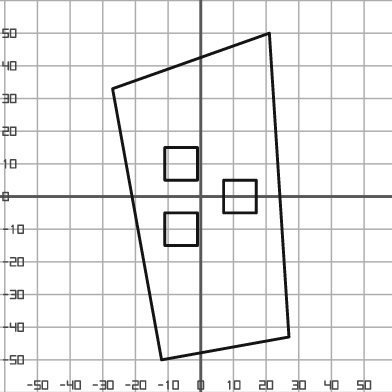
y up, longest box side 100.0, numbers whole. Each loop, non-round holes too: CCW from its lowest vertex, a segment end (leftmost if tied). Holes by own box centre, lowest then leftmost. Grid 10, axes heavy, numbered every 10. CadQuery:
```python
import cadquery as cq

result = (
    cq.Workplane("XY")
    .moveTo(-12.0, -50.0)
    .lineTo(27.0, -43.0)
    .lineTo(21.0, 50.0)
    .lineTo(-27.0, 33.0)
    .close()
    .moveTo(-11.0, -15.0)
    .lineTo(-1.0, -15.0)
    .lineTo(-1.0, -5.0)
    .lineTo(-11.0, -5.0)
    .close()
    .moveTo(7.0, -5.0)
    .lineTo(17.0, -5.0)
    .lineTo(17.0, 5.0)
    .lineTo(7.0, 5.0)
    .close()
    .moveTo(-11.0, 5.0)
    .lineTo(-1.0, 5.0)
    .lineTo(-1.0, 15.0)
    .lineTo(-11.0, 15.0)
    .close()
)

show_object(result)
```